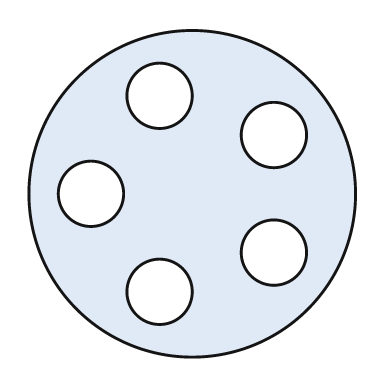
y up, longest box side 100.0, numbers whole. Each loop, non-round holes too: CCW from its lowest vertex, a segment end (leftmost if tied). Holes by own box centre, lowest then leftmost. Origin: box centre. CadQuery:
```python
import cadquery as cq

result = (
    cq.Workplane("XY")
    .moveTo(0.0, 0.0)
    .circle(50.0)
    .moveTo(-10.0, -30.0)
    .circle(10.0)
    .moveTo(25.0, -18.0)
    .circle(10.0)
    .moveTo(-31.0, 0.0)
    .circle(10.0)
    .moveTo(25.0, 18.0)
    .circle(10.0)
    .moveTo(-10.0, 30.0)
    .circle(10.0)
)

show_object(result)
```